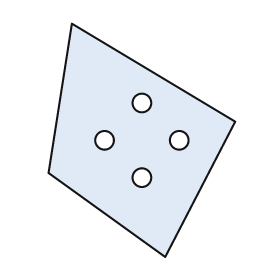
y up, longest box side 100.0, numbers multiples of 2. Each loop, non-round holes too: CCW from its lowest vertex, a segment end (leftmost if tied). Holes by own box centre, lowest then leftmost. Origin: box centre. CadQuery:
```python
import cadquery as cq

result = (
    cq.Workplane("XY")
    .moveTo(10.0, -50.0)
    .lineTo(40.0, 8.0)
    .lineTo(-30.0, 50.0)
    .lineTo(-40.0, -14.0)
    .close()
    .moveTo(0.0, -16.0)
    .circle(4.0)
    .moveTo(-16.0, 0.0)
    .circle(4.0)
    .moveTo(16.0, 0.0)
    .circle(4.0)
    .moveTo(0.0, 16.0)
    .circle(4.0)
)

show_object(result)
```